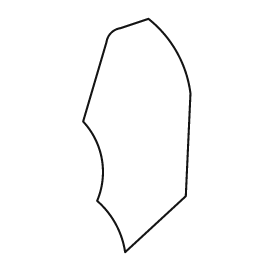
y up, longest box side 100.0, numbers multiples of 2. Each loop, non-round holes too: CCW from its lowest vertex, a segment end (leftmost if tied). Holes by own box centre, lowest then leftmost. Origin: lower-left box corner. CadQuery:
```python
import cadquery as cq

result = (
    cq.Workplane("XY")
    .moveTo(18.0, 0.0)
    .lineTo(44.0, 24.0)
    .lineTo(46.0, 68.0)
    .threePointArc((40.0, 86.0), (28.0, 100.0))
    .lineTo(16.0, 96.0)
    .threePointArc((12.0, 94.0), (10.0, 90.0))
    .lineTo(0.0, 56.0)
    .threePointArc((8.0, 40.0), (6.0, 22.0))
    .threePointArc((14.0, 12.0), (18.0, 0.0))
    .close()
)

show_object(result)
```